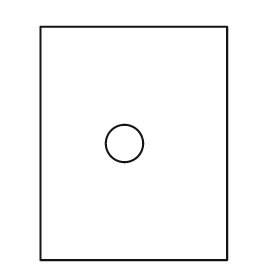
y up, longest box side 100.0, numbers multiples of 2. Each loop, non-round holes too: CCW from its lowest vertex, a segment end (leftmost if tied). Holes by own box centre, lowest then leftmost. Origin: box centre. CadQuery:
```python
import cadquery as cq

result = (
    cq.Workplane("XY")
    .moveTo(-40.0, -50.0)
    .lineTo(40.0, -50.0)
    .lineTo(40.0, 50.0)
    .lineTo(-40.0, 50.0)
    .close()
    .moveTo(-4.0, 0.0)
    .circle(8.0)
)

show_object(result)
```